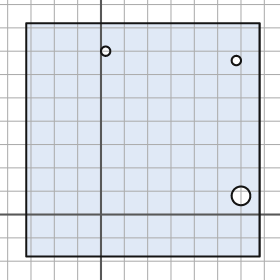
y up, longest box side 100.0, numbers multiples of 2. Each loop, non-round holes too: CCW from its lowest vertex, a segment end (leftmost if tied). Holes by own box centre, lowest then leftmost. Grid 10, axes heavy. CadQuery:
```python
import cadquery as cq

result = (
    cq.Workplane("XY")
    .moveTo(-32.0, -18.0)
    .lineTo(68.0, -18.0)
    .lineTo(68.0, 82.0)
    .lineTo(-32.0, 82.0)
    .close()
    .moveTo(60.0, 8.0)
    .circle(4.0)
    .moveTo(58.0, 66.0)
    .circle(2.0)
    .moveTo(2.0, 70.0)
    .circle(2.0)
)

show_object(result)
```